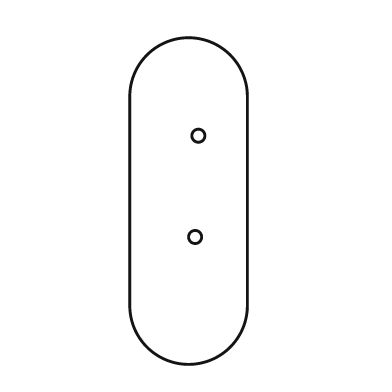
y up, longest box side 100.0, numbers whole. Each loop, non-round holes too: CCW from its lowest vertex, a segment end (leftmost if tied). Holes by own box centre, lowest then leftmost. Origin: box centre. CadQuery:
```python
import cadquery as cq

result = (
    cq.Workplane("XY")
    .moveTo(-18.0, -32.0)
    .threePointArc((0.0, -50.0), (18.0, -32.0))
    .lineTo(18.0, 32.0)
    .threePointArc((0.0, 50.0), (-18.0, 32.0))
    .close()
    .moveTo(2.0, -11.0)
    .circle(2.0)
    .moveTo(3.0, 20.0)
    .circle(2.0)
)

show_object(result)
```